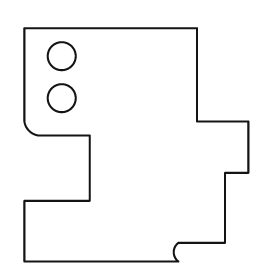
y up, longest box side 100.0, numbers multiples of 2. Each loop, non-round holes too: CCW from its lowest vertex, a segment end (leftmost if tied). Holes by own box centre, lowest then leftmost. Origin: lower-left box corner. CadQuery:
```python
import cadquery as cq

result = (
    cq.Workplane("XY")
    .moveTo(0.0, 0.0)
    .lineTo(66.0, 0.0)
    .threePointArc((64.0, 4.0), (66.0, 8.0))
    .lineTo(86.0, 8.0)
    .lineTo(86.0, 38.0)
    .lineTo(96.0, 38.0)
    .lineTo(96.0, 60.0)
    .lineTo(74.0, 60.0)
    .lineTo(74.0, 100.0)
    .lineTo(0.0, 100.0)
    .lineTo(0.0, 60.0)
    .threePointArc((2.0, 56.0), (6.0, 54.0))
    .lineTo(28.0, 54.0)
    .lineTo(28.0, 26.0)
    .lineTo(0.0, 26.0)
    .close()
    .moveTo(16.0, 70.0)
    .circle(6.0)
    .moveTo(16.0, 88.0)
    .circle(6.0)
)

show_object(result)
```